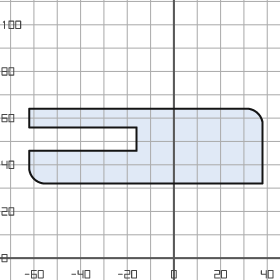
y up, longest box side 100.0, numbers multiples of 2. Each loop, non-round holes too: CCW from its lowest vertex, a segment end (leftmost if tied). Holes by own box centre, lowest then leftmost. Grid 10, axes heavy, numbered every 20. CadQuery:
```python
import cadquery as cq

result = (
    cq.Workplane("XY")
    .moveTo(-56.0, 32.0)
    .lineTo(38.0, 32.0)
    .lineTo(38.0, 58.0)
    .threePointArc((36.0, 62.0), (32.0, 64.0))
    .lineTo(-62.0, 64.0)
    .lineTo(-62.0, 56.0)
    .lineTo(-16.0, 56.0)
    .lineTo(-16.0, 46.0)
    .lineTo(-62.0, 46.0)
    .lineTo(-62.0, 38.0)
    .threePointArc((-60.0, 34.0), (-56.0, 32.0))
    .close()
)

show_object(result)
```